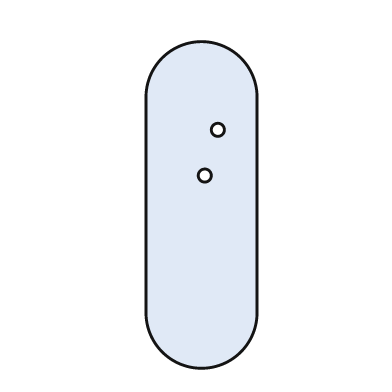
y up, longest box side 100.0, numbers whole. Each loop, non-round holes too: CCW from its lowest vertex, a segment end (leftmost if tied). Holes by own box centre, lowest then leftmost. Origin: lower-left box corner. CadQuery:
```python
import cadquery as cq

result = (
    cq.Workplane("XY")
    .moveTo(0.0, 17.0)
    .threePointArc((17.0, 0.0), (34.0, 17.0))
    .lineTo(34.0, 83.0)
    .threePointArc((17.0, 100.0), (0.0, 83.0))
    .close()
    .moveTo(18.0, 59.0)
    .circle(2.0)
    .moveTo(22.0, 73.0)
    .circle(2.0)
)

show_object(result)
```